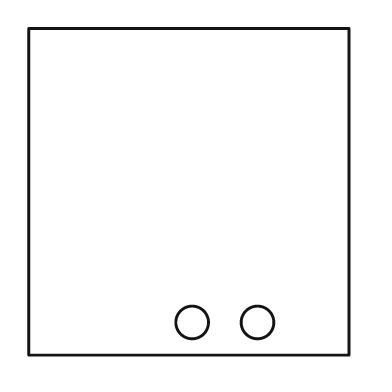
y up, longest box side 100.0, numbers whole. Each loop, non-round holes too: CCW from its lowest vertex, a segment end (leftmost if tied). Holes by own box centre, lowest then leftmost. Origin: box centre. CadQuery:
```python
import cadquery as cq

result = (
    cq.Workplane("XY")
    .moveTo(-49.0, -50.0)
    .lineTo(49.0, -50.0)
    .lineTo(49.0, 50.0)
    .lineTo(-49.0, 50.0)
    .close()
    .moveTo(1.0, -40.0)
    .circle(5.0)
    .moveTo(21.0, -40.0)
    .circle(5.0)
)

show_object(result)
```